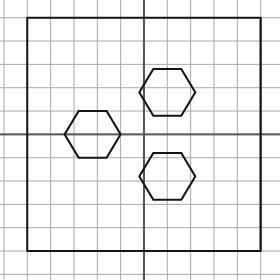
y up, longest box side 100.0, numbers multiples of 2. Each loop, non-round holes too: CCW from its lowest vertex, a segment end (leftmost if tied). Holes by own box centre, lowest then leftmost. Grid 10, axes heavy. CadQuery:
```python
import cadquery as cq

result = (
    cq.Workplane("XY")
    .moveTo(-50.0, -50.0)
    .lineTo(50.0, -50.0)
    .lineTo(50.0, 50.0)
    .lineTo(-50.0, 50.0)
    .close()
    .moveTo(4.0, -28.0)
    .lineTo(16.0, -28.0)
    .lineTo(22.0, -18.0)
    .lineTo(16.0, -8.0)
    .lineTo(4.0, -8.0)
    .lineTo(-2.0, -18.0)
    .close()
    .moveTo(-28.0, -10.0)
    .lineTo(-16.0, -10.0)
    .lineTo(-10.0, 0.0)
    .lineTo(-16.0, 10.0)
    .lineTo(-28.0, 10.0)
    .lineTo(-34.0, 0.0)
    .close()
    .moveTo(4.0, 8.0)
    .lineTo(16.0, 8.0)
    .lineTo(22.0, 18.0)
    .lineTo(16.0, 28.0)
    .lineTo(4.0, 28.0)
    .lineTo(-2.0, 18.0)
    .close()
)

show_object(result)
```